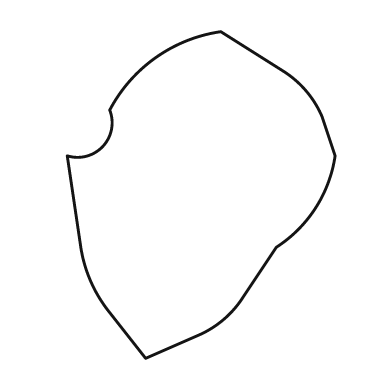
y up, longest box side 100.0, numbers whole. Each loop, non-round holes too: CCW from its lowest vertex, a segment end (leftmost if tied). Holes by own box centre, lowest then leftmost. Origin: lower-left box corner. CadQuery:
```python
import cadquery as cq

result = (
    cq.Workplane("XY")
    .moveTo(24.0, 0.0)
    .lineTo(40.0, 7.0)
    .threePointArc((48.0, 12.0), (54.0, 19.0))
    .lineTo(64.0, 34.0)
    .threePointArc((76.0, 46.0), (82.0, 62.0))
    .lineTo(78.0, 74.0)
    .threePointArc((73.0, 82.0), (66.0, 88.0))
    .lineTo(47.0, 100.0)
    .threePointArc((27.0, 92.0), (13.0, 76.0))
    .threePointArc((11.0, 65.0), (0.0, 62.0))
    .lineTo(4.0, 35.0)
    .threePointArc((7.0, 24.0), (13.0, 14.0))
    .close()
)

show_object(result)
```